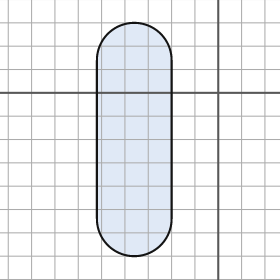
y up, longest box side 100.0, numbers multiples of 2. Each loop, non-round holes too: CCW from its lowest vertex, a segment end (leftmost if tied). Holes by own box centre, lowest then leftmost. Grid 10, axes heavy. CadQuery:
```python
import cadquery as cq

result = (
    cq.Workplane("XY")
    .moveTo(-52.0, -54.0)
    .threePointArc((-36.0, -70.0), (-20.0, -54.0))
    .lineTo(-20.0, 14.0)
    .threePointArc((-36.0, 30.0), (-52.0, 14.0))
    .close()
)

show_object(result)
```